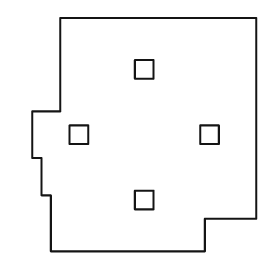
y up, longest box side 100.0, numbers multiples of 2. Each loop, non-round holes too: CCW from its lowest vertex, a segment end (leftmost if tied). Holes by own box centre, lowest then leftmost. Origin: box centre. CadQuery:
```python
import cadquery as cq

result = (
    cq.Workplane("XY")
    .moveTo(-40.0, -50.0)
    .lineTo(26.0, -50.0)
    .lineTo(26.0, -36.0)
    .lineTo(48.0, -36.0)
    .lineTo(48.0, 50.0)
    .lineTo(-36.0, 50.0)
    .lineTo(-36.0, 10.0)
    .lineTo(-48.0, 10.0)
    .lineTo(-48.0, -10.0)
    .lineTo(-44.0, -10.0)
    .lineTo(-44.0, -26.0)
    .lineTo(-40.0, -26.0)
    .close()
    .moveTo(-4.0, -32.0)
    .lineTo(4.0, -32.0)
    .lineTo(4.0, -24.0)
    .lineTo(-4.0, -24.0)
    .close()
    .moveTo(-32.0, -4.0)
    .lineTo(-24.0, -4.0)
    .lineTo(-24.0, 4.0)
    .lineTo(-32.0, 4.0)
    .close()
    .moveTo(24.0, -4.0)
    .lineTo(32.0, -4.0)
    .lineTo(32.0, 4.0)
    .lineTo(24.0, 4.0)
    .close()
    .moveTo(-4.0, 24.0)
    .lineTo(4.0, 24.0)
    .lineTo(4.0, 32.0)
    .lineTo(-4.0, 32.0)
    .close()
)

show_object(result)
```